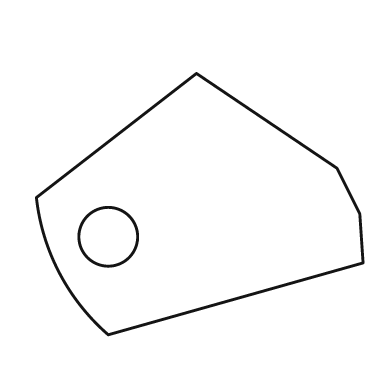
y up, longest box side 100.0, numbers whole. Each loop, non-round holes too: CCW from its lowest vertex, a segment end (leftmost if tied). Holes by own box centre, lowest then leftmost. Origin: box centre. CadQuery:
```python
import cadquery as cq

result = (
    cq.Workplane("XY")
    .moveTo(-28.0, -40.0)
    .lineTo(50.0, -18.0)
    .lineTo(49.0, -3.0)
    .lineTo(42.0, 11.0)
    .lineTo(-1.0, 40.0)
    .lineTo(-50.0, 2.0)
    .threePointArc((-43.0, -21.0), (-28.0, -40.0))
    .close()
    .moveTo(-28.0, -10.0)
    .circle(9.0)
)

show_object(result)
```